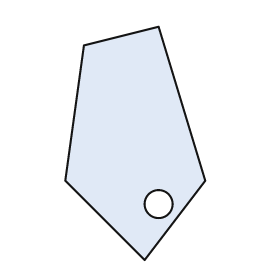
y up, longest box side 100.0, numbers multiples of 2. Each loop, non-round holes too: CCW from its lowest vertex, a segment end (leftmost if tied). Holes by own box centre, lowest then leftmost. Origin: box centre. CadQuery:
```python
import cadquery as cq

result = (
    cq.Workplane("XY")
    .moveTo(4.0, -50.0)
    .lineTo(30.0, -16.0)
    .lineTo(10.0, 50.0)
    .lineTo(-22.0, 42.0)
    .lineTo(-30.0, -16.0)
    .close()
    .moveTo(10.0, -26.0)
    .circle(6.0)
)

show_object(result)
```